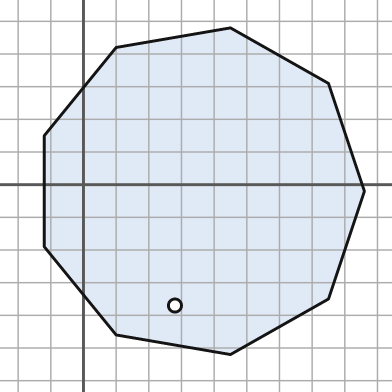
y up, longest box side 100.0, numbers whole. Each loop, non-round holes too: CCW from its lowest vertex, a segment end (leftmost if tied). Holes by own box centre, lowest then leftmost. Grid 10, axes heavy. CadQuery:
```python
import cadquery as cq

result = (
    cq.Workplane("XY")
    .moveTo(45.0, -52.0)
    .lineTo(75.0, -35.0)
    .lineTo(86.0, -2.0)
    .lineTo(75.0, 31.0)
    .lineTo(45.0, 48.0)
    .lineTo(10.0, 42.0)
    .lineTo(-12.0, 15.0)
    .lineTo(-12.0, -19.0)
    .lineTo(10.0, -46.0)
    .close()
    .moveTo(28.0, -37.0)
    .circle(2.0)
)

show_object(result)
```